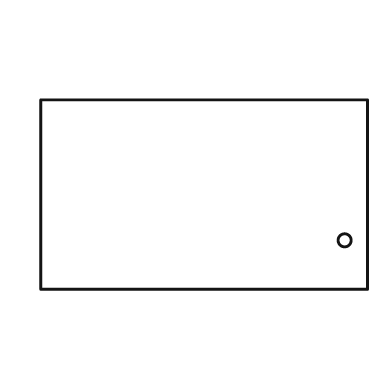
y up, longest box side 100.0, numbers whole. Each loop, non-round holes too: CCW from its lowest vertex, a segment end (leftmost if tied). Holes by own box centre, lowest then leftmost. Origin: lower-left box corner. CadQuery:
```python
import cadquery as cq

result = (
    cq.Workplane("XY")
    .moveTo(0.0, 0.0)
    .lineTo(100.0, 0.0)
    .lineTo(100.0, 58.0)
    .lineTo(0.0, 58.0)
    .close()
    .moveTo(93.0, 15.0)
    .circle(2.0)
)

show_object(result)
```